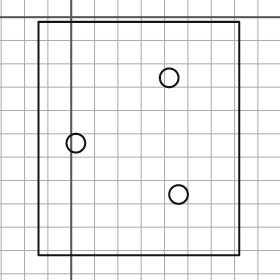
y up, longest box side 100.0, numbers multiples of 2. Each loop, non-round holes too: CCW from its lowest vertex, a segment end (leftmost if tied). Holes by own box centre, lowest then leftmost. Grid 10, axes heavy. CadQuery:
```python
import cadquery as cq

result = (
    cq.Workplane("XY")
    .moveTo(-14.0, -102.0)
    .lineTo(72.0, -102.0)
    .lineTo(72.0, -2.0)
    .lineTo(-14.0, -2.0)
    .close()
    .moveTo(46.0, -76.0)
    .circle(4.0)
    .moveTo(2.0, -54.0)
    .circle(4.0)
    .moveTo(42.0, -26.0)
    .circle(4.0)
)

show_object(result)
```